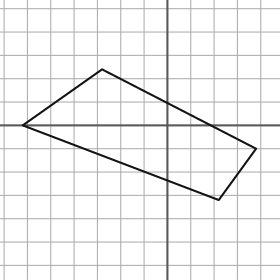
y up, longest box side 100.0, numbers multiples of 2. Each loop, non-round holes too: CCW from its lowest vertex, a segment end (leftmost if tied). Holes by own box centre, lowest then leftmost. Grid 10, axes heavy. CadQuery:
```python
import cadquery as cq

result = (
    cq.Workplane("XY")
    .moveTo(22.0, -32.0)
    .lineTo(38.0, -10.0)
    .lineTo(-28.0, 24.0)
    .lineTo(-62.0, 0.0)
    .close()
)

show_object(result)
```